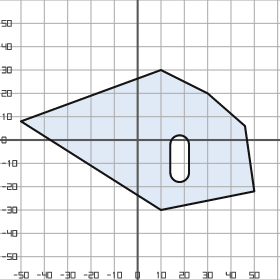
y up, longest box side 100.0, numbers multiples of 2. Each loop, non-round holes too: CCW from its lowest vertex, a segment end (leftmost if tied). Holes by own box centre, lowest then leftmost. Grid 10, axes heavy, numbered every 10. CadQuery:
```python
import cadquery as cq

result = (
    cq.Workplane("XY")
    .moveTo(10.0, -30.0)
    .lineTo(50.0, -22.0)
    .lineTo(46.0, 6.0)
    .lineTo(30.0, 20.0)
    .lineTo(10.0, 30.0)
    .lineTo(-50.0, 8.0)
    .close()
    .moveTo(14.0, -14.0)
    .threePointArc((18.0, -18.0), (22.0, -14.0))
    .lineTo(22.0, -2.0)
    .threePointArc((18.0, 2.0), (14.0, -2.0))
    .close()
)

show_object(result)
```